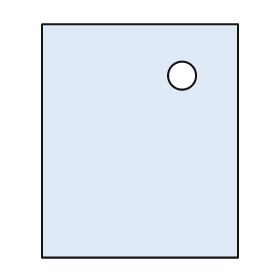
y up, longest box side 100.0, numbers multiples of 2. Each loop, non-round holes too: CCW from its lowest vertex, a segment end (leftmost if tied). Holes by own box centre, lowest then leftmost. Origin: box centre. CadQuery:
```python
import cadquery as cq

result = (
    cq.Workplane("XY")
    .moveTo(-42.0, -50.0)
    .lineTo(42.0, -50.0)
    .lineTo(42.0, 50.0)
    .lineTo(-42.0, 50.0)
    .close()
    .moveTo(18.0, 28.0)
    .circle(6.0)
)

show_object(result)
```